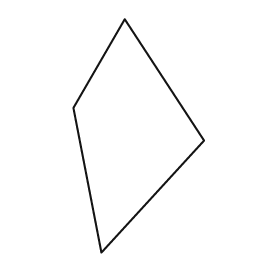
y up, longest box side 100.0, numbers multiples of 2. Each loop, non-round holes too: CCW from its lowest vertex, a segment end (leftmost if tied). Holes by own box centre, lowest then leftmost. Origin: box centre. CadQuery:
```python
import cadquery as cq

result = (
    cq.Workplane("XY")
    .moveTo(-16.0, -50.0)
    .lineTo(28.0, -2.0)
    .lineTo(-6.0, 50.0)
    .lineTo(-28.0, 12.0)
    .close()
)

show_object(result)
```